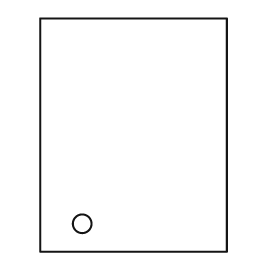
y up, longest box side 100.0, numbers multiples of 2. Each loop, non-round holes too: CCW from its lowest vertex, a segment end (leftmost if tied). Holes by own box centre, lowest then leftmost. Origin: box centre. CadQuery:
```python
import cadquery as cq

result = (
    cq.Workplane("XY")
    .moveTo(-40.0, -50.0)
    .lineTo(40.0, -50.0)
    .lineTo(40.0, 50.0)
    .lineTo(-40.0, 50.0)
    .close()
    .moveTo(-22.0, -38.0)
    .circle(4.0)
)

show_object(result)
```